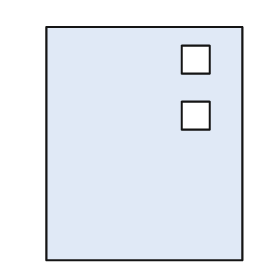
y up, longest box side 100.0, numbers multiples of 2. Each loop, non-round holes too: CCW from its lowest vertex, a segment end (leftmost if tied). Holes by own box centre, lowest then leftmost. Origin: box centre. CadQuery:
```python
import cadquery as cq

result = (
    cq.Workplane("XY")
    .moveTo(-42.0, -50.0)
    .lineTo(42.0, -50.0)
    .lineTo(42.0, 50.0)
    .lineTo(-42.0, 50.0)
    .close()
    .moveTo(16.0, 6.0)
    .lineTo(28.0, 6.0)
    .lineTo(28.0, 18.0)
    .lineTo(16.0, 18.0)
    .close()
    .moveTo(16.0, 30.0)
    .lineTo(28.0, 30.0)
    .lineTo(28.0, 42.0)
    .lineTo(16.0, 42.0)
    .close()
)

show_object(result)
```